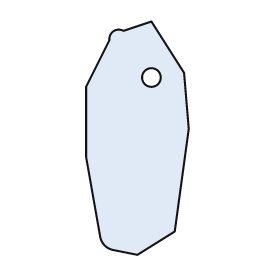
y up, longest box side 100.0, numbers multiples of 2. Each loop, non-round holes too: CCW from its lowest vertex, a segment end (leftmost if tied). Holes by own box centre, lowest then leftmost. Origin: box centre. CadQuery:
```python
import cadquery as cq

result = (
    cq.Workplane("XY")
    .moveTo(0.0, -50.0)
    .lineTo(16.0, -40.0)
    .lineTo(22.0, 4.0)
    .lineTo(20.0, 28.0)
    .lineTo(6.0, 50.0)
    .lineTo(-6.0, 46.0)
    .threePointArc((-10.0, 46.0), (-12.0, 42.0))
    .lineTo(-22.0, 22.0)
    .lineTo(-22.0, -8.0)
    .lineTo(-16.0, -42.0)
    .threePointArc((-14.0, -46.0), (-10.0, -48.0))
    .close()
    .moveTo(6.0, 26.0)
    .circle(4.0)
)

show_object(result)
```